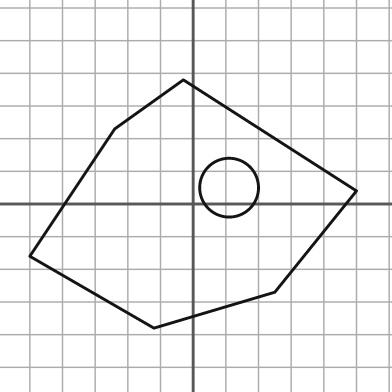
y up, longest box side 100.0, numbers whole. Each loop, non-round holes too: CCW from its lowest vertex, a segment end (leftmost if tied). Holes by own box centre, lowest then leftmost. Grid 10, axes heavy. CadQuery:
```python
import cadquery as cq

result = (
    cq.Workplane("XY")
    .moveTo(-12.0, -38.0)
    .lineTo(25.0, -27.0)
    .lineTo(50.0, 4.0)
    .lineTo(-3.0, 38.0)
    .lineTo(-24.0, 23.0)
    .lineTo(-50.0, -16.0)
    .close()
    .moveTo(11.0, 5.0)
    .circle(9.0)
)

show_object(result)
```